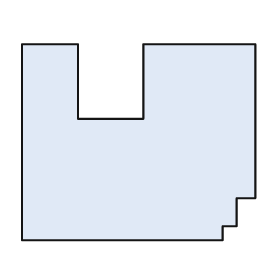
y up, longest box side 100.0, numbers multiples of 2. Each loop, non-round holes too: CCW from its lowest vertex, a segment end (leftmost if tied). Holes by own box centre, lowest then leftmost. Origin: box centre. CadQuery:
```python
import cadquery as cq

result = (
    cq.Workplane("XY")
    .moveTo(-50.0, -42.0)
    .lineTo(36.0, -42.0)
    .lineTo(36.0, -36.0)
    .lineTo(42.0, -36.0)
    .lineTo(42.0, -24.0)
    .lineTo(50.0, -24.0)
    .lineTo(50.0, 42.0)
    .lineTo(2.0, 42.0)
    .lineTo(2.0, 10.0)
    .lineTo(-26.0, 10.0)
    .lineTo(-26.0, 42.0)
    .lineTo(-50.0, 42.0)
    .close()
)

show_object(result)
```